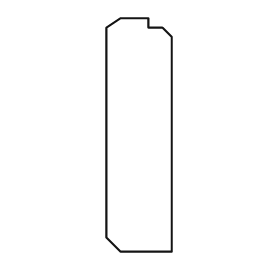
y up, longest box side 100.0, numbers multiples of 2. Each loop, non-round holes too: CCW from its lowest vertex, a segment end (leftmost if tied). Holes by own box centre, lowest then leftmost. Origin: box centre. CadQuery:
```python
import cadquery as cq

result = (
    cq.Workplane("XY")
    .moveTo(-8.0, -50.0)
    .lineTo(14.0, -50.0)
    .lineTo(14.0, 42.0)
    .lineTo(10.0, 46.0)
    .lineTo(4.0, 46.0)
    .lineTo(4.0, 50.0)
    .lineTo(-8.0, 50.0)
    .lineTo(-14.0, 46.0)
    .lineTo(-14.0, -44.0)
    .close()
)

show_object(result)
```